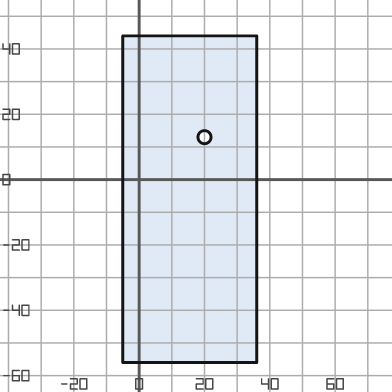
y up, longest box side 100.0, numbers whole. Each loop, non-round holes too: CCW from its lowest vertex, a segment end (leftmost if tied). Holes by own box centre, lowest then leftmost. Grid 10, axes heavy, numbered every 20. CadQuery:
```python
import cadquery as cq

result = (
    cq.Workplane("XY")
    .moveTo(-5.0, -56.0)
    .lineTo(36.0, -56.0)
    .lineTo(36.0, 44.0)
    .lineTo(-5.0, 44.0)
    .close()
    .moveTo(20.0, 13.0)
    .circle(2.0)
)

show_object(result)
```